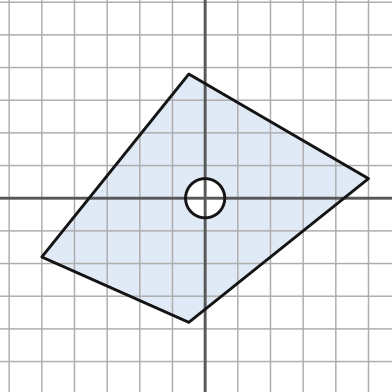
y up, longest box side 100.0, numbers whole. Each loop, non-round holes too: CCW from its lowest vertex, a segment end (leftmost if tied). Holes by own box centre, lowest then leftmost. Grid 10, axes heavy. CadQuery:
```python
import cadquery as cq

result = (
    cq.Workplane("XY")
    .moveTo(-5.0, -38.0)
    .lineTo(50.0, 6.0)
    .lineTo(-5.0, 38.0)
    .lineTo(-50.0, -18.0)
    .close()
    .moveTo(0.0, 0.0)
    .circle(6.0)
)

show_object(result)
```